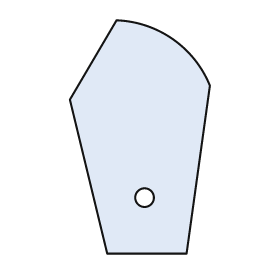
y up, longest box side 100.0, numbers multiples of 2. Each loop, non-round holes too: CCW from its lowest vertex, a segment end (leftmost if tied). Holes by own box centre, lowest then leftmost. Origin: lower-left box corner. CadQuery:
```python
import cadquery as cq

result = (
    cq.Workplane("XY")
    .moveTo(16.0, 0.0)
    .lineTo(50.0, 0.0)
    .lineTo(60.0, 72.0)
    .threePointArc((44.0, 92.0), (20.0, 100.0))
    .lineTo(0.0, 66.0)
    .close()
    .moveTo(32.0, 24.0)
    .circle(4.0)
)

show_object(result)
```